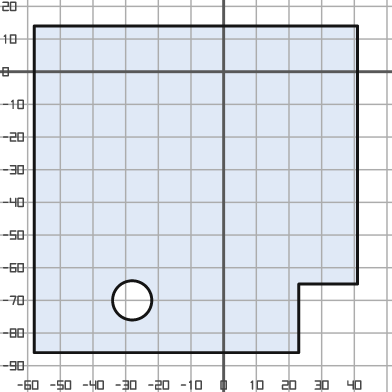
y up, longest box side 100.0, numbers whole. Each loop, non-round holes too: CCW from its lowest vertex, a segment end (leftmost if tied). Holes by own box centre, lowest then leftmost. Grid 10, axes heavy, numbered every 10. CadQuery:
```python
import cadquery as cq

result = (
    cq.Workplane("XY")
    .moveTo(-58.0, -86.0)
    .lineTo(23.0, -86.0)
    .lineTo(23.0, -65.0)
    .lineTo(41.0, -65.0)
    .lineTo(41.0, 14.0)
    .lineTo(-58.0, 14.0)
    .close()
    .moveTo(-28.0, -70.0)
    .circle(6.0)
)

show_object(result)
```